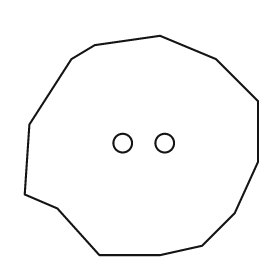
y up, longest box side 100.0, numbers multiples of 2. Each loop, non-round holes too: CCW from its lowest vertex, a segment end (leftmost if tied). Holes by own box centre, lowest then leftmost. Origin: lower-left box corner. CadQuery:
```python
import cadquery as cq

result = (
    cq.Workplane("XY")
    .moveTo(32.0, 0.0)
    .lineTo(58.0, 0.0)
    .lineTo(76.0, 4.0)
    .lineTo(90.0, 18.0)
    .lineTo(100.0, 40.0)
    .lineTo(100.0, 66.0)
    .lineTo(82.0, 84.0)
    .lineTo(58.0, 94.0)
    .lineTo(30.0, 90.0)
    .lineTo(20.0, 84.0)
    .lineTo(2.0, 56.0)
    .lineTo(0.0, 26.0)
    .lineTo(14.0, 20.0)
    .close()
    .moveTo(42.0, 48.0)
    .circle(4.0)
    .moveTo(60.0, 48.0)
    .circle(4.0)
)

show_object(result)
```